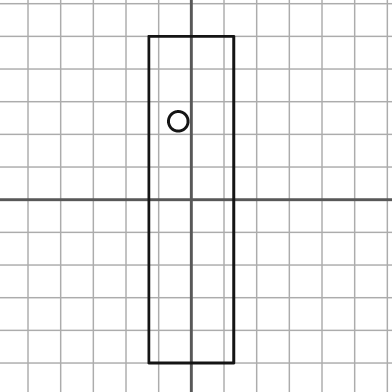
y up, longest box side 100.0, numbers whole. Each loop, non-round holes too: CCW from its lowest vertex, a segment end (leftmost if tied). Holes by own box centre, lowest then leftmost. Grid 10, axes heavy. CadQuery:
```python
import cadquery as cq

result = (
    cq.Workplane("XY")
    .moveTo(-13.0, -50.0)
    .lineTo(13.0, -50.0)
    .lineTo(13.0, 50.0)
    .lineTo(-13.0, 50.0)
    .close()
    .moveTo(-4.0, 24.0)
    .circle(3.0)
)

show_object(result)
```